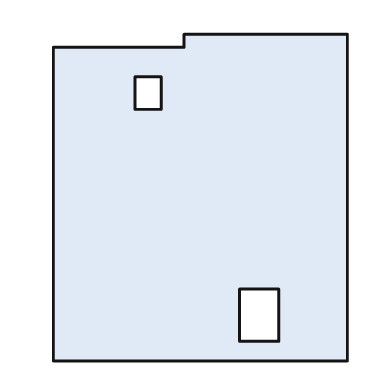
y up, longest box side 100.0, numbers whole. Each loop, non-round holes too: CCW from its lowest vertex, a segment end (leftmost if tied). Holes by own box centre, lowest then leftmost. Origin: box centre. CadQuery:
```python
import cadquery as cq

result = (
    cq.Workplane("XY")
    .moveTo(-45.0, -50.0)
    .lineTo(45.0, -50.0)
    .lineTo(45.0, 50.0)
    .lineTo(-5.0, 50.0)
    .lineTo(-5.0, 46.0)
    .lineTo(-45.0, 46.0)
    .close()
    .moveTo(12.0, -44.0)
    .lineTo(24.0, -44.0)
    .lineTo(24.0, -28.0)
    .lineTo(12.0, -28.0)
    .close()
    .moveTo(-20.0, 27.0)
    .lineTo(-12.0, 27.0)
    .lineTo(-12.0, 37.0)
    .lineTo(-20.0, 37.0)
    .close()
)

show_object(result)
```